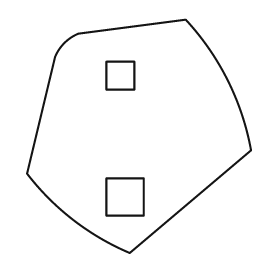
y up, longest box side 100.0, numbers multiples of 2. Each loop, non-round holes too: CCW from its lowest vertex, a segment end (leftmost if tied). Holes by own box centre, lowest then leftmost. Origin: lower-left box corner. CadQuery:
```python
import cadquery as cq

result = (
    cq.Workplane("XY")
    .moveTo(44.0, 0.0)
    .lineTo(96.0, 44.0)
    .threePointArc((86.0, 74.0), (68.0, 100.0))
    .lineTo(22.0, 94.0)
    .threePointArc((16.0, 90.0), (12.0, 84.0))
    .lineTo(0.0, 34.0)
    .threePointArc((20.0, 14.0), (44.0, 0.0))
    .close()
    .moveTo(34.0, 16.0)
    .lineTo(50.0, 16.0)
    .lineTo(50.0, 32.0)
    .lineTo(34.0, 32.0)
    .close()
    .moveTo(34.0, 70.0)
    .lineTo(46.0, 70.0)
    .lineTo(46.0, 82.0)
    .lineTo(34.0, 82.0)
    .close()
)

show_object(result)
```